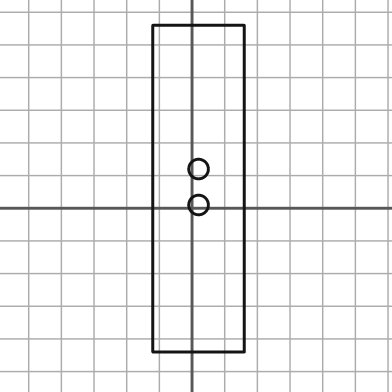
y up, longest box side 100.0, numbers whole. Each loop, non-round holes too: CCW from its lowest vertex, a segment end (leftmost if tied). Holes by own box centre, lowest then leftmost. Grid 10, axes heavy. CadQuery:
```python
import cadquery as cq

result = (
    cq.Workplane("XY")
    .moveTo(-12.0, -44.0)
    .lineTo(16.0, -44.0)
    .lineTo(16.0, 56.0)
    .lineTo(-12.0, 56.0)
    .close()
    .moveTo(2.0, 1.0)
    .circle(3.0)
    .moveTo(2.0, 12.0)
    .circle(3.0)
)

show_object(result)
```